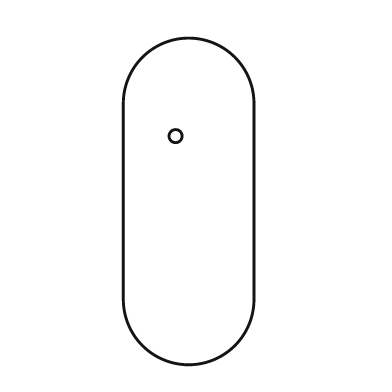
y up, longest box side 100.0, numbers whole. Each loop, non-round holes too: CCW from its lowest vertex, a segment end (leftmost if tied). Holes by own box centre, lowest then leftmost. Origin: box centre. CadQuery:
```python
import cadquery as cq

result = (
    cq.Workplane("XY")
    .moveTo(-20.0, -30.0)
    .threePointArc((0.0, -50.0), (20.0, -30.0))
    .lineTo(20.0, 30.0)
    .threePointArc((0.0, 50.0), (-20.0, 30.0))
    .close()
    .moveTo(-4.0, 20.0)
    .circle(2.0)
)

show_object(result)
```